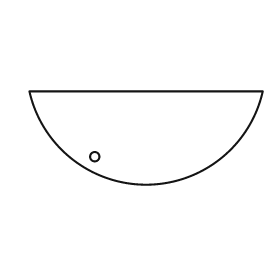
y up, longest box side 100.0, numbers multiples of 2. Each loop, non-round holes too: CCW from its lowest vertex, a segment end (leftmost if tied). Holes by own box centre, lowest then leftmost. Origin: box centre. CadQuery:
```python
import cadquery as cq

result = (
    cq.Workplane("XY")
    .moveTo(-50.0, 20.0)
    .threePointArc((0.0, -20.0), (50.0, 20.0))
    .close()
    .moveTo(-22.0, -8.0)
    .circle(2.0)
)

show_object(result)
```